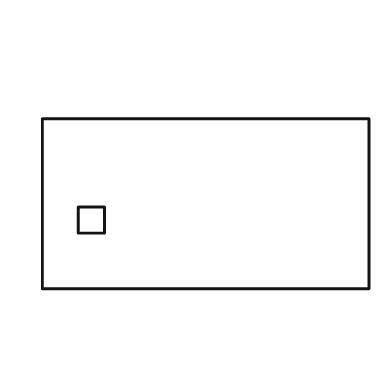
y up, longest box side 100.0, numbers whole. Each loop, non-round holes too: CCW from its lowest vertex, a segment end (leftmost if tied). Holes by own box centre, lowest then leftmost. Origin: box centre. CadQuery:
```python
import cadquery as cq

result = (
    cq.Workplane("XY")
    .moveTo(-50.0, -26.0)
    .lineTo(50.0, -26.0)
    .lineTo(50.0, 26.0)
    .lineTo(-50.0, 26.0)
    .close()
    .moveTo(-39.0, -9.0)
    .lineTo(-31.0, -9.0)
    .lineTo(-31.0, -1.0)
    .lineTo(-39.0, -1.0)
    .close()
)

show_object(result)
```